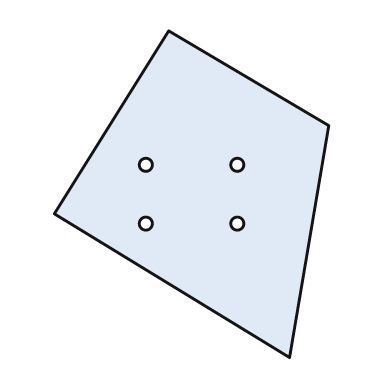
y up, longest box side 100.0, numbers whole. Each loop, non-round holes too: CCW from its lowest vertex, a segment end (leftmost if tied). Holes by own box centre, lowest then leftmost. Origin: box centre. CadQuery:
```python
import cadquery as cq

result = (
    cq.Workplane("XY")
    .moveTo(30.0, -50.0)
    .lineTo(42.0, 21.0)
    .lineTo(-7.0, 50.0)
    .lineTo(-42.0, -6.0)
    .close()
    .moveTo(-14.0, -9.0)
    .circle(2.0)
    .moveTo(14.0, -9.0)
    .circle(2.0)
    .moveTo(-14.0, 9.0)
    .circle(2.0)
    .moveTo(14.0, 9.0)
    .circle(2.0)
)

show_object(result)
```